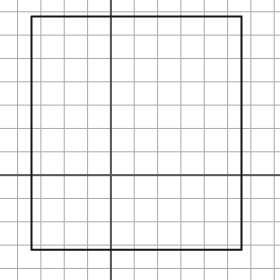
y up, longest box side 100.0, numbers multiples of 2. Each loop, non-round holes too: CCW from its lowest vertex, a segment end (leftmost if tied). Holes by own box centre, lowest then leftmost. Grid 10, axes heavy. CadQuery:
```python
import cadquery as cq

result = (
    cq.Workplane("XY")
    .moveTo(-34.0, -32.0)
    .lineTo(56.0, -32.0)
    .lineTo(56.0, 68.0)
    .lineTo(-34.0, 68.0)
    .close()
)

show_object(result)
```